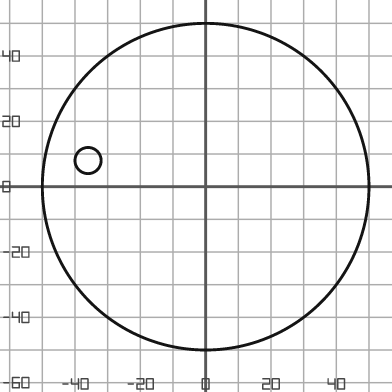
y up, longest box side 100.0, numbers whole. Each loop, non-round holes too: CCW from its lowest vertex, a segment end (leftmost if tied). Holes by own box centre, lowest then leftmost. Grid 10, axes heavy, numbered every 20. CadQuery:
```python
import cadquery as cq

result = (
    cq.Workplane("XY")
    .moveTo(0.0, 0.0)
    .circle(50.0)
    .moveTo(-36.0, 8.0)
    .circle(4.0)
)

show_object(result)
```